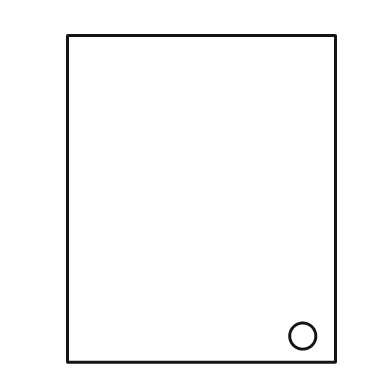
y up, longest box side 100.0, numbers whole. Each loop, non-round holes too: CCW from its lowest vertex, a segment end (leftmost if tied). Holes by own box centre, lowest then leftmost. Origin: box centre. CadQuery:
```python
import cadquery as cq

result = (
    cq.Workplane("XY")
    .moveTo(-41.0, -50.0)
    .lineTo(41.0, -50.0)
    .lineTo(41.0, 50.0)
    .lineTo(-41.0, 50.0)
    .close()
    .moveTo(31.0, -42.0)
    .circle(4.0)
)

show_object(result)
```